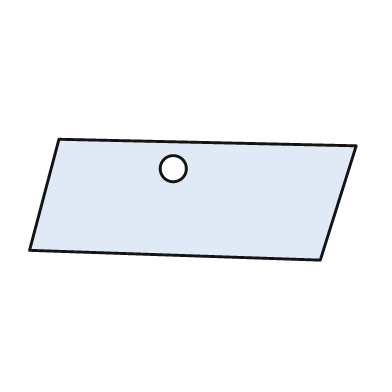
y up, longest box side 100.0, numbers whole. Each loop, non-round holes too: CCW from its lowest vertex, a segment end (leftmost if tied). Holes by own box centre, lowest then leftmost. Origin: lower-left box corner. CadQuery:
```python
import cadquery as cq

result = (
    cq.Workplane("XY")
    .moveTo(89.0, 0.0)
    .lineTo(100.0, 35.0)
    .lineTo(9.0, 37.0)
    .lineTo(0.0, 3.0)
    .close()
    .moveTo(44.0, 28.0)
    .circle(4.0)
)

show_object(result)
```